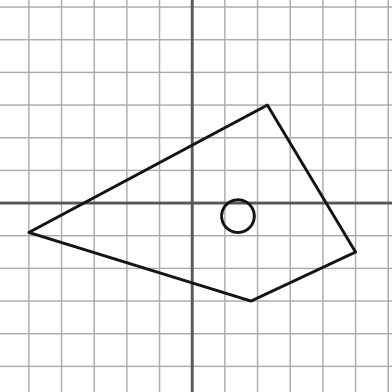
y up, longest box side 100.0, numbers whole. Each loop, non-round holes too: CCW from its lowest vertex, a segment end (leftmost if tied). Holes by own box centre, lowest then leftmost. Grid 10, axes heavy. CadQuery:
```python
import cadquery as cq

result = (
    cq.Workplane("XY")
    .moveTo(18.0, -30.0)
    .lineTo(50.0, -15.0)
    .lineTo(23.0, 30.0)
    .lineTo(-50.0, -9.0)
    .close()
    .moveTo(14.0, -4.0)
    .circle(5.0)
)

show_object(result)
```